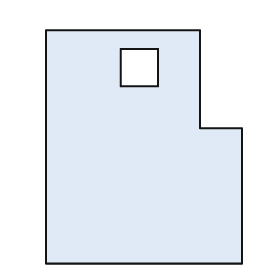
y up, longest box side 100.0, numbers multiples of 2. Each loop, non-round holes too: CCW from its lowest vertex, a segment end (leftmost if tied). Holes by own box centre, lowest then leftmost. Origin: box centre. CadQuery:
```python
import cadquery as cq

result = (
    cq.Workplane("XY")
    .moveTo(-42.0, -50.0)
    .lineTo(42.0, -50.0)
    .lineTo(42.0, 8.0)
    .lineTo(24.0, 8.0)
    .lineTo(24.0, 50.0)
    .lineTo(-42.0, 50.0)
    .close()
    .moveTo(-10.0, 26.0)
    .lineTo(6.0, 26.0)
    .lineTo(6.0, 42.0)
    .lineTo(-10.0, 42.0)
    .close()
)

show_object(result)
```